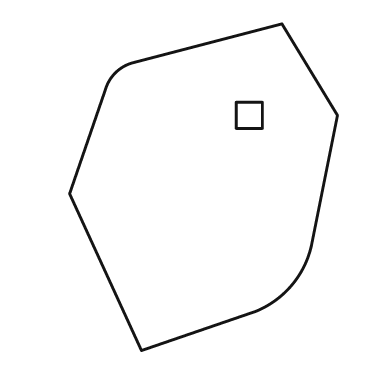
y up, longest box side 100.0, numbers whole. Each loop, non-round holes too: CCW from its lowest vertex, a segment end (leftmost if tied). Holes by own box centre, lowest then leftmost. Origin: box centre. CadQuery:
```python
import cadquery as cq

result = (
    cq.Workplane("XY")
    .moveTo(-19.0, -50.0)
    .lineTo(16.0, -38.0)
    .threePointArc((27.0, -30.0), (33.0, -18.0))
    .lineTo(41.0, 22.0)
    .lineTo(24.0, 50.0)
    .lineTo(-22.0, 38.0)
    .threePointArc((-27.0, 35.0), (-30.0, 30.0))
    .lineTo(-41.0, -2.0)
    .close()
    .moveTo(10.0, 18.0)
    .lineTo(18.0, 18.0)
    .lineTo(18.0, 26.0)
    .lineTo(10.0, 26.0)
    .close()
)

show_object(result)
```